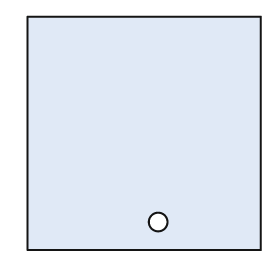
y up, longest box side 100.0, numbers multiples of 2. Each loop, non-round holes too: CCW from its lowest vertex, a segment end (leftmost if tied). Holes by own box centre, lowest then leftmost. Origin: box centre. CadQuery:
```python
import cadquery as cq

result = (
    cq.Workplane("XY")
    .moveTo(-50.0, -50.0)
    .lineTo(50.0, -50.0)
    .lineTo(50.0, 50.0)
    .lineTo(-50.0, 50.0)
    .close()
    .moveTo(6.0, -38.0)
    .circle(4.0)
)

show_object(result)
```